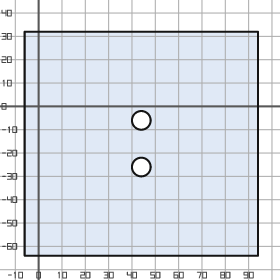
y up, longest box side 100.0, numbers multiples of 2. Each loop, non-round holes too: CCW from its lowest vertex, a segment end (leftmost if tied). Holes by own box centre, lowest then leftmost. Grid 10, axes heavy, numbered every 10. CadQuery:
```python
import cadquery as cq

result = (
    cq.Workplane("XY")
    .moveTo(-6.0, -64.0)
    .lineTo(94.0, -64.0)
    .lineTo(94.0, 32.0)
    .lineTo(-6.0, 32.0)
    .close()
    .moveTo(44.0, -26.0)
    .circle(4.0)
    .moveTo(44.0, -6.0)
    .circle(4.0)
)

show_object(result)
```